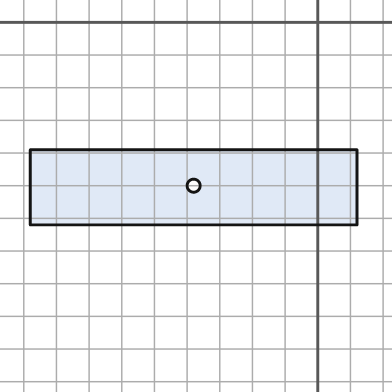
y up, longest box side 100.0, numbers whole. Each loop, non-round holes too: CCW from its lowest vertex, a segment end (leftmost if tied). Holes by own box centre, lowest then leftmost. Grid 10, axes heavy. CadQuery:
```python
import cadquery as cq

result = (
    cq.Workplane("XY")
    .moveTo(-88.0, -62.0)
    .lineTo(12.0, -62.0)
    .lineTo(12.0, -39.0)
    .lineTo(-88.0, -39.0)
    .close()
    .moveTo(-38.0, -50.0)
    .circle(2.0)
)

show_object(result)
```